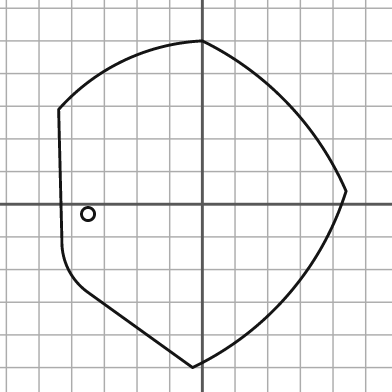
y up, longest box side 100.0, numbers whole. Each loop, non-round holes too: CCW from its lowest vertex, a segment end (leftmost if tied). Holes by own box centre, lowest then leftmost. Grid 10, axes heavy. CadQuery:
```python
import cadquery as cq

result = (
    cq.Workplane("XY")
    .moveTo(-3.0, -50.0)
    .threePointArc((26.0, -28.0), (44.0, 4.0))
    .threePointArc((26.0, 31.0), (0.0, 50.0))
    .threePointArc((-24.0, 44.0), (-44.0, 29.0))
    .lineTo(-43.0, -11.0)
    .threePointArc((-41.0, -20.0), (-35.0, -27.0))
    .close()
    .moveTo(-35.0, -3.0)
    .circle(2.0)
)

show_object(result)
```